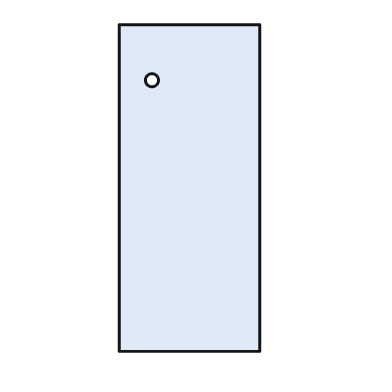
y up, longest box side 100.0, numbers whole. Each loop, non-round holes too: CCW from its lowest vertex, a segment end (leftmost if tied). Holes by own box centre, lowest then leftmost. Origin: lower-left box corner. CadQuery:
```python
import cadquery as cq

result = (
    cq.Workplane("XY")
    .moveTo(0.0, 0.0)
    .lineTo(43.0, 0.0)
    .lineTo(43.0, 100.0)
    .lineTo(0.0, 100.0)
    .close()
    .moveTo(10.0, 83.0)
    .circle(2.0)
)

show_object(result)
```